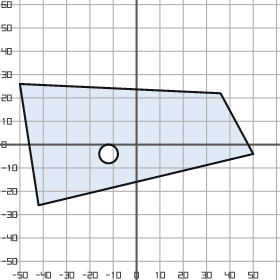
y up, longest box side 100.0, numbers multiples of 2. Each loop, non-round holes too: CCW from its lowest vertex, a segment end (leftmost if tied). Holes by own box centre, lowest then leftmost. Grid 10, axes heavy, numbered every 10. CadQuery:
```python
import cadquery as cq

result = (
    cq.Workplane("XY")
    .moveTo(-42.0, -26.0)
    .lineTo(50.0, -4.0)
    .lineTo(36.0, 22.0)
    .lineTo(-50.0, 26.0)
    .close()
    .moveTo(-12.0, -4.0)
    .circle(4.0)
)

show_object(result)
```